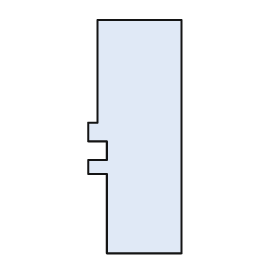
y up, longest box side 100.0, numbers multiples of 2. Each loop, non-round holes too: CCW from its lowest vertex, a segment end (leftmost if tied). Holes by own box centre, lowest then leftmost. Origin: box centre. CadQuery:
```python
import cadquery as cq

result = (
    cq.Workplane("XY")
    .moveTo(-12.0, -50.0)
    .lineTo(20.0, -50.0)
    .lineTo(20.0, 50.0)
    .lineTo(-16.0, 50.0)
    .lineTo(-16.0, 6.0)
    .lineTo(-20.0, 6.0)
    .lineTo(-20.0, -2.0)
    .lineTo(-12.0, -2.0)
    .lineTo(-12.0, -10.0)
    .lineTo(-20.0, -10.0)
    .lineTo(-20.0, -16.0)
    .lineTo(-12.0, -16.0)
    .close()
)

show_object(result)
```